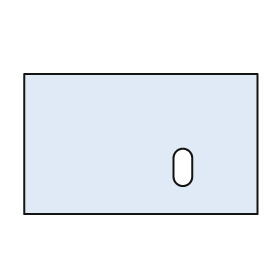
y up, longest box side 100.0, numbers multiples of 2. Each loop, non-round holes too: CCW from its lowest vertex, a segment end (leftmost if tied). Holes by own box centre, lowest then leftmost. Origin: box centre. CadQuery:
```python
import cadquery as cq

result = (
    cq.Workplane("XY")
    .moveTo(-50.0, -30.0)
    .lineTo(50.0, -30.0)
    .lineTo(50.0, 30.0)
    .lineTo(-50.0, 30.0)
    .close()
    .moveTo(14.0, -14.0)
    .threePointArc((18.0, -18.0), (22.0, -14.0))
    .lineTo(22.0, -6.0)
    .threePointArc((18.0, -2.0), (14.0, -6.0))
    .close()
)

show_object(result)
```